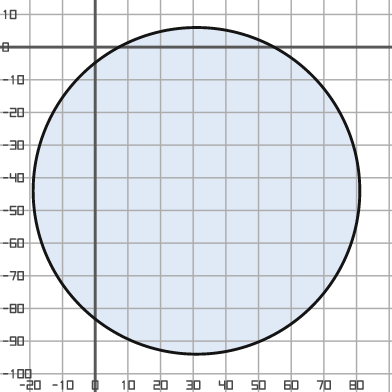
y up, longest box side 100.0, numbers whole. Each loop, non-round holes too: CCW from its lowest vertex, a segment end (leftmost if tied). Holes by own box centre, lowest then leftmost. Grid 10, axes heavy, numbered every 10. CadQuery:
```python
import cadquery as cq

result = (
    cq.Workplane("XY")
    .moveTo(31.0, -44.0)
    .circle(50.0)
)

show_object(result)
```